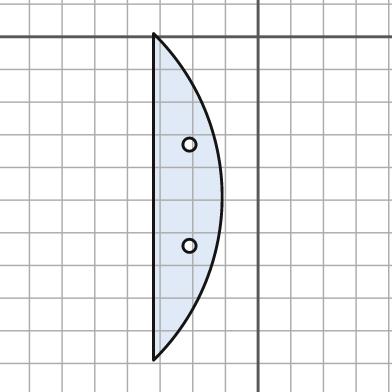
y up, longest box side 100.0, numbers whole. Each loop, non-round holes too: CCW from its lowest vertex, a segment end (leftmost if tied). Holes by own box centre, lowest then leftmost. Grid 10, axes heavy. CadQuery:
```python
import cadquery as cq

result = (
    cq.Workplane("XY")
    .moveTo(-32.0, -99.0)
    .threePointArc((-11.0, -49.0), (-32.0, 1.0))
    .close()
    .moveTo(-21.0, -64.0)
    .circle(2.0)
    .moveTo(-21.0, -33.0)
    .circle(2.0)
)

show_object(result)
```